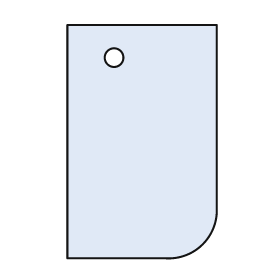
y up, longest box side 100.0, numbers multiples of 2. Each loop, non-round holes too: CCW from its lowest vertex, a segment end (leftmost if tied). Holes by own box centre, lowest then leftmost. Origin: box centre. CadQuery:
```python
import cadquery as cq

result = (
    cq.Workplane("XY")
    .moveTo(-32.0, -50.0)
    .lineTo(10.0, -50.0)
    .threePointArc((26.0, -44.0), (32.0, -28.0))
    .lineTo(32.0, 50.0)
    .lineTo(-32.0, 50.0)
    .close()
    .moveTo(-12.0, 36.0)
    .circle(4.0)
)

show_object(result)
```